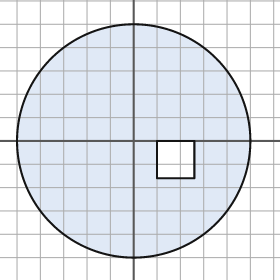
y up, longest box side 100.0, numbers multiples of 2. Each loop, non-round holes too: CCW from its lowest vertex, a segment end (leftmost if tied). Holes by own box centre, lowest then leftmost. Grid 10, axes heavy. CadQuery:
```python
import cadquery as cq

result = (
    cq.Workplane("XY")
    .moveTo(0.0, 0.0)
    .circle(50.0)
    .moveTo(10.0, -16.0)
    .lineTo(26.0, -16.0)
    .lineTo(26.0, 0.0)
    .lineTo(10.0, 0.0)
    .close()
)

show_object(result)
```